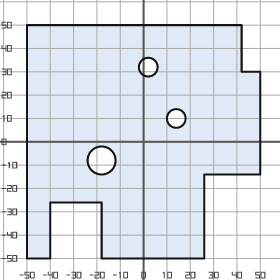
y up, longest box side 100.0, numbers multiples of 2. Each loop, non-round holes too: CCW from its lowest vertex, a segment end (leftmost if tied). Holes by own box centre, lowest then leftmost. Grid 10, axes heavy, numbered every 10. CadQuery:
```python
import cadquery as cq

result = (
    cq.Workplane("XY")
    .moveTo(-50.0, -50.0)
    .lineTo(-40.0, -50.0)
    .lineTo(-40.0, -26.0)
    .lineTo(-18.0, -26.0)
    .lineTo(-18.0, -50.0)
    .lineTo(26.0, -50.0)
    .lineTo(26.0, -14.0)
    .lineTo(50.0, -14.0)
    .lineTo(50.0, 30.0)
    .lineTo(42.0, 30.0)
    .lineTo(42.0, 50.0)
    .lineTo(-50.0, 50.0)
    .close()
    .moveTo(-18.0, -8.0)
    .circle(6.0)
    .moveTo(14.0, 10.0)
    .circle(4.0)
    .moveTo(2.0, 32.0)
    .circle(4.0)
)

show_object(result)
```